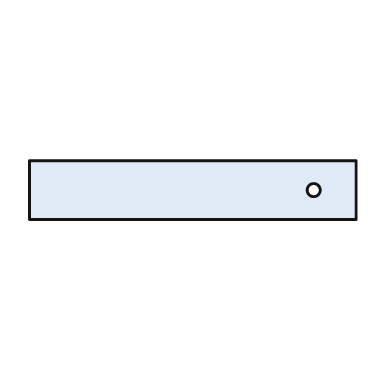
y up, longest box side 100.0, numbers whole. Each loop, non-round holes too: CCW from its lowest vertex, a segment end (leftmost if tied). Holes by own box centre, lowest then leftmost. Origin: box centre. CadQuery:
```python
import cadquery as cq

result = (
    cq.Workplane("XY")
    .moveTo(-50.0, -9.0)
    .lineTo(50.0, -9.0)
    .lineTo(50.0, 9.0)
    .lineTo(-50.0, 9.0)
    .close()
    .moveTo(37.0, 0.0)
    .circle(2.0)
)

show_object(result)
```